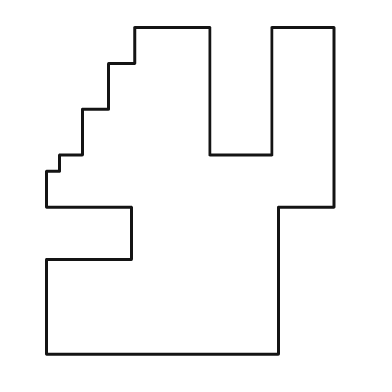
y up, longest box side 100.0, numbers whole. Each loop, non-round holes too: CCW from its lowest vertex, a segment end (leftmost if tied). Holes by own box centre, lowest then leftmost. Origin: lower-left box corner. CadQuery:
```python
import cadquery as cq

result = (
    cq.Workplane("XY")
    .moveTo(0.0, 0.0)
    .lineTo(71.0, 0.0)
    .lineTo(71.0, 45.0)
    .lineTo(88.0, 45.0)
    .lineTo(88.0, 100.0)
    .lineTo(69.0, 100.0)
    .lineTo(69.0, 61.0)
    .lineTo(50.0, 61.0)
    .lineTo(50.0, 100.0)
    .lineTo(27.0, 100.0)
    .lineTo(27.0, 89.0)
    .lineTo(19.0, 89.0)
    .lineTo(19.0, 75.0)
    .lineTo(11.0, 75.0)
    .lineTo(11.0, 61.0)
    .lineTo(4.0, 61.0)
    .lineTo(4.0, 56.0)
    .lineTo(0.0, 56.0)
    .lineTo(0.0, 45.0)
    .lineTo(26.0, 45.0)
    .lineTo(26.0, 29.0)
    .lineTo(0.0, 29.0)
    .close()
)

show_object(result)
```